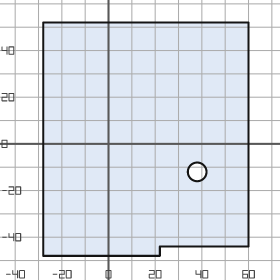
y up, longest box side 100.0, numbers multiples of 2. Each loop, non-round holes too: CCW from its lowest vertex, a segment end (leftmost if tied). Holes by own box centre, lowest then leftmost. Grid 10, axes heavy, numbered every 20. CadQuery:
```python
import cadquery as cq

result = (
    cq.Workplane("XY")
    .moveTo(-28.0, -48.0)
    .lineTo(22.0, -48.0)
    .lineTo(22.0, -44.0)
    .lineTo(60.0, -44.0)
    .lineTo(60.0, 52.0)
    .lineTo(-28.0, 52.0)
    .close()
    .moveTo(38.0, -12.0)
    .circle(4.0)
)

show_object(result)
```